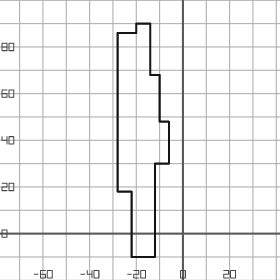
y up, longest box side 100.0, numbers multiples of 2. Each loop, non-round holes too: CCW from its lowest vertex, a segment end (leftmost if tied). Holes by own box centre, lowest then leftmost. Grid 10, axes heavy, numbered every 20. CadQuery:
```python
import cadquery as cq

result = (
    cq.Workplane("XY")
    .moveTo(-22.0, -10.0)
    .lineTo(-12.0, -10.0)
    .lineTo(-12.0, 30.0)
    .lineTo(-6.0, 30.0)
    .lineTo(-6.0, 48.0)
    .lineTo(-10.0, 48.0)
    .lineTo(-10.0, 68.0)
    .lineTo(-14.0, 68.0)
    .lineTo(-14.0, 90.0)
    .lineTo(-20.0, 90.0)
    .lineTo(-20.0, 86.0)
    .lineTo(-28.0, 86.0)
    .lineTo(-28.0, 18.0)
    .lineTo(-22.0, 18.0)
    .close()
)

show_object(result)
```